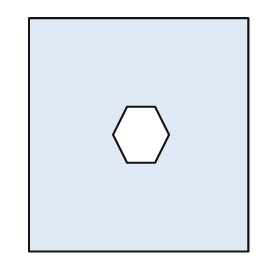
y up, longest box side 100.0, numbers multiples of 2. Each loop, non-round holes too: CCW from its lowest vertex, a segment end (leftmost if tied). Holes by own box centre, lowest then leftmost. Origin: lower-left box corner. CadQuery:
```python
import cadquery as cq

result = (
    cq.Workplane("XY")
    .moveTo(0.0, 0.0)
    .lineTo(94.0, 0.0)
    .lineTo(94.0, 100.0)
    .lineTo(0.0, 100.0)
    .close()
    .moveTo(42.0, 38.0)
    .lineTo(54.0, 38.0)
    .lineTo(60.0, 50.0)
    .lineTo(54.0, 62.0)
    .lineTo(42.0, 62.0)
    .lineTo(36.0, 50.0)
    .close()
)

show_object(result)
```